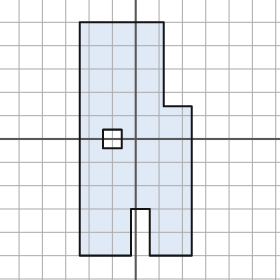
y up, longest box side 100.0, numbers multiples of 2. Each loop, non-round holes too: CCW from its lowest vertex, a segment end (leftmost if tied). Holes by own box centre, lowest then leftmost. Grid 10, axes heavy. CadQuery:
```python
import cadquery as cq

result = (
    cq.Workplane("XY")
    .moveTo(-24.0, -50.0)
    .lineTo(-2.0, -50.0)
    .lineTo(-2.0, -30.0)
    .lineTo(6.0, -30.0)
    .lineTo(6.0, -50.0)
    .lineTo(24.0, -50.0)
    .lineTo(24.0, 14.0)
    .lineTo(12.0, 14.0)
    .lineTo(12.0, 50.0)
    .lineTo(-24.0, 50.0)
    .close()
    .moveTo(-14.0, -4.0)
    .lineTo(-6.0, -4.0)
    .lineTo(-6.0, 4.0)
    .lineTo(-14.0, 4.0)
    .close()
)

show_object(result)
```